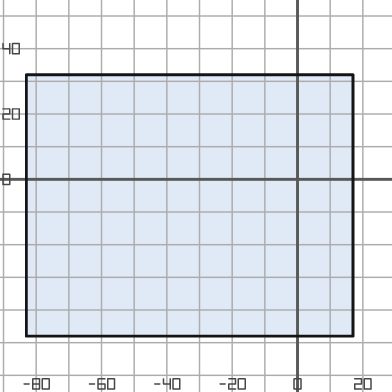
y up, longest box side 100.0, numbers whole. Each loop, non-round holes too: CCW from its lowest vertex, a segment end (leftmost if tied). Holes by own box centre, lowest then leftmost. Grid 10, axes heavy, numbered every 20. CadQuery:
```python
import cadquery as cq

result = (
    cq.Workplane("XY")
    .moveTo(-83.0, -48.0)
    .lineTo(17.0, -48.0)
    .lineTo(17.0, 32.0)
    .lineTo(-83.0, 32.0)
    .close()
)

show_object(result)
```